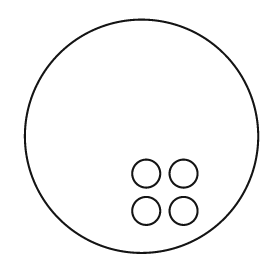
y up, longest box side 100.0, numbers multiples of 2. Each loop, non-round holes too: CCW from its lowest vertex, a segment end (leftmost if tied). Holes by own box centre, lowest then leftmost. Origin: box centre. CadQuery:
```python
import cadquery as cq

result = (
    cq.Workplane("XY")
    .moveTo(0.0, 0.0)
    .circle(50.0)
    .moveTo(2.0, -32.0)
    .circle(6.0)
    .moveTo(18.0, -32.0)
    .circle(6.0)
    .moveTo(2.0, -16.0)
    .circle(6.0)
    .moveTo(18.0, -16.0)
    .circle(6.0)
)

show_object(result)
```